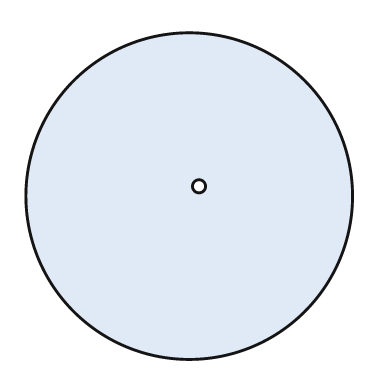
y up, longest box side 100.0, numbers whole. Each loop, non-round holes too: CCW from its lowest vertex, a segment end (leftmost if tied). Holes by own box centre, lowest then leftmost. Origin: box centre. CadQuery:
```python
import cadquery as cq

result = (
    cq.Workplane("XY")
    .moveTo(0.0, 0.0)
    .circle(50.0)
    .moveTo(3.0, 3.0)
    .circle(2.0)
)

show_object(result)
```